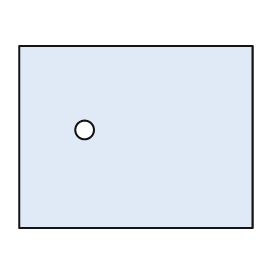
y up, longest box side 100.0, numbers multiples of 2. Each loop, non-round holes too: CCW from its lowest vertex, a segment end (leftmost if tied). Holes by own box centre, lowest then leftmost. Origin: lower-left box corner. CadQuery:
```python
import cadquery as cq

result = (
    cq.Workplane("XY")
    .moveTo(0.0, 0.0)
    .lineTo(100.0, 0.0)
    .lineTo(100.0, 78.0)
    .lineTo(0.0, 78.0)
    .close()
    .moveTo(28.0, 42.0)
    .circle(4.0)
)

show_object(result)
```